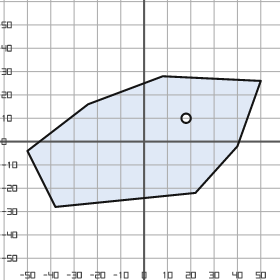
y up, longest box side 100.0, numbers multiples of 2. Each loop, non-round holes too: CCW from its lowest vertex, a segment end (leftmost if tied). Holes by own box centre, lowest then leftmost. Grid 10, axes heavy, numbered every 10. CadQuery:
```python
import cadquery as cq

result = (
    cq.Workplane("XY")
    .moveTo(-38.0, -28.0)
    .lineTo(22.0, -22.0)
    .lineTo(40.0, -2.0)
    .lineTo(50.0, 26.0)
    .lineTo(8.0, 28.0)
    .lineTo(-24.0, 16.0)
    .lineTo(-50.0, -4.0)
    .close()
    .moveTo(18.0, 10.0)
    .circle(2.0)
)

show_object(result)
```